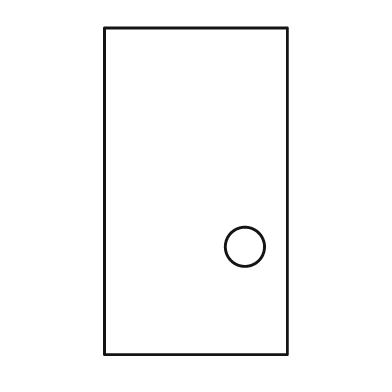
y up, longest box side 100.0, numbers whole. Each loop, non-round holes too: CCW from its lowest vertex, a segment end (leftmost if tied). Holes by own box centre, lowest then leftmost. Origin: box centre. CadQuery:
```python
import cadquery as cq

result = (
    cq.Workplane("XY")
    .moveTo(-28.0, -50.0)
    .lineTo(28.0, -50.0)
    .lineTo(28.0, 50.0)
    .lineTo(-28.0, 50.0)
    .close()
    .moveTo(15.0, -17.0)
    .circle(6.0)
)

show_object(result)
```